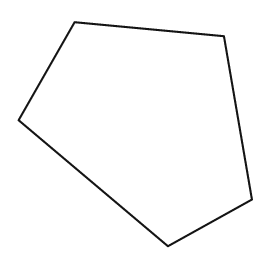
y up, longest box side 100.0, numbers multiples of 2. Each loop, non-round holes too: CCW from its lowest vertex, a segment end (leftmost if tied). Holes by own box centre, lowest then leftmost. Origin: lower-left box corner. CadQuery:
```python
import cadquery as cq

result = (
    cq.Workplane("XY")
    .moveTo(64.0, 0.0)
    .lineTo(100.0, 20.0)
    .lineTo(88.0, 90.0)
    .lineTo(24.0, 96.0)
    .lineTo(0.0, 54.0)
    .close()
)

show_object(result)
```